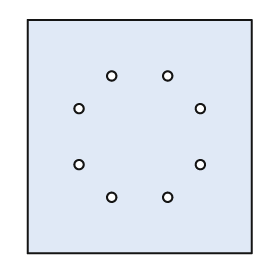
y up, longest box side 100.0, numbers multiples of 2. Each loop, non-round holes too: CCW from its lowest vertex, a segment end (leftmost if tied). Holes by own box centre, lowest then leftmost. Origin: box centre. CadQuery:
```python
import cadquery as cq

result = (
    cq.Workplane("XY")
    .moveTo(-48.0, -50.0)
    .lineTo(48.0, -50.0)
    .lineTo(48.0, 50.0)
    .lineTo(-48.0, 50.0)
    .close()
    .moveTo(-12.0, -26.0)
    .circle(2.0)
    .moveTo(12.0, -26.0)
    .circle(2.0)
    .moveTo(-26.0, -12.0)
    .circle(2.0)
    .moveTo(26.0, -12.0)
    .circle(2.0)
    .moveTo(-26.0, 12.0)
    .circle(2.0)
    .moveTo(26.0, 12.0)
    .circle(2.0)
    .moveTo(-12.0, 26.0)
    .circle(2.0)
    .moveTo(12.0, 26.0)
    .circle(2.0)
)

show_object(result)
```